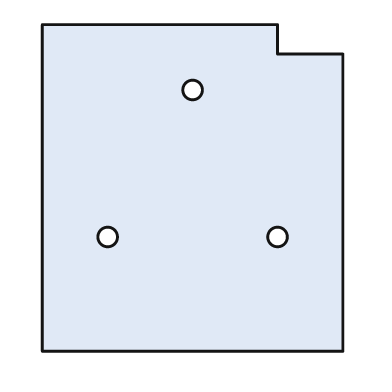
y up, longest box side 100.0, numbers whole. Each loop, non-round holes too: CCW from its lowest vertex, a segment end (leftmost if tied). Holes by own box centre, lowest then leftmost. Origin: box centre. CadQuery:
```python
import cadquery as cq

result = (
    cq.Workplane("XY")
    .moveTo(-46.0, -50.0)
    .lineTo(46.0, -50.0)
    .lineTo(46.0, 41.0)
    .lineTo(26.0, 41.0)
    .lineTo(26.0, 50.0)
    .lineTo(-46.0, 50.0)
    .close()
    .moveTo(-26.0, -15.0)
    .circle(3.0)
    .moveTo(26.0, -15.0)
    .circle(3.0)
    .moveTo(0.0, 30.0)
    .circle(3.0)
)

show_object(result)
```